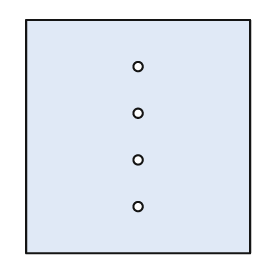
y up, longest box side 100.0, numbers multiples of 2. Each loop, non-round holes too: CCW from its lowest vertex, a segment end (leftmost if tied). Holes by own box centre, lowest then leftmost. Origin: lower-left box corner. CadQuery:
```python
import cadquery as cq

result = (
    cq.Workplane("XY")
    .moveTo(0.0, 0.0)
    .lineTo(96.0, 0.0)
    .lineTo(96.0, 100.0)
    .lineTo(0.0, 100.0)
    .close()
    .moveTo(48.0, 20.0)
    .circle(2.0)
    .moveTo(48.0, 40.0)
    .circle(2.0)
    .moveTo(48.0, 60.0)
    .circle(2.0)
    .moveTo(48.0, 80.0)
    .circle(2.0)
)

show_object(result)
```